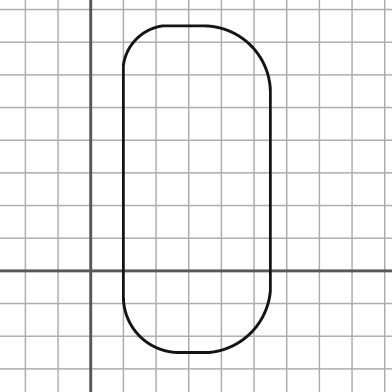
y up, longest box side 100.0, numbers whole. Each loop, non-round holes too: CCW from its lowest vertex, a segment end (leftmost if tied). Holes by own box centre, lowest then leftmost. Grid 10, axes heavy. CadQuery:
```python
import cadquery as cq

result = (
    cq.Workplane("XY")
    .moveTo(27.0, -25.0)
    .lineTo(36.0, -25.0)
    .threePointArc((49.0, -19.0), (55.0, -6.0))
    .lineTo(55.0, 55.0)
    .threePointArc((49.0, 69.0), (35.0, 75.0))
    .lineTo(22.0, 75.0)
    .threePointArc((14.0, 71.0), (10.0, 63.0))
    .lineTo(10.0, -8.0)
    .threePointArc((15.0, -20.0), (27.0, -25.0))
    .close()
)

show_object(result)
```